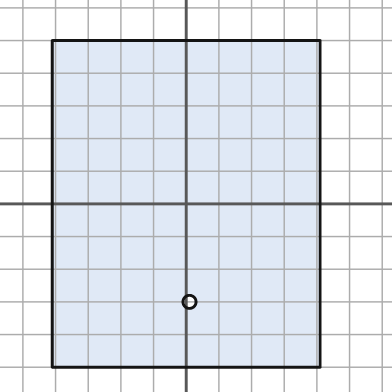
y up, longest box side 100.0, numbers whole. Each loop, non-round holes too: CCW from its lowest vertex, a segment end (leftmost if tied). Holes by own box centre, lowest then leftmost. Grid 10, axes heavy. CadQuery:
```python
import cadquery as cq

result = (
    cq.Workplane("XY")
    .moveTo(-41.0, -50.0)
    .lineTo(41.0, -50.0)
    .lineTo(41.0, 50.0)
    .lineTo(-41.0, 50.0)
    .close()
    .moveTo(1.0, -30.0)
    .circle(2.0)
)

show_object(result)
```